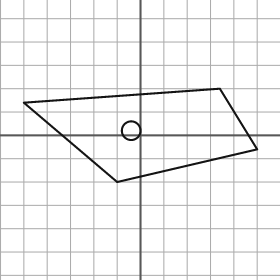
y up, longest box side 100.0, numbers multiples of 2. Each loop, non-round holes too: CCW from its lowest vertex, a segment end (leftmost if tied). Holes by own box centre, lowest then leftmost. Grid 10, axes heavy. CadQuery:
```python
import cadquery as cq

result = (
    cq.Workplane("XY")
    .moveTo(-10.0, -20.0)
    .lineTo(50.0, -6.0)
    .lineTo(34.0, 20.0)
    .lineTo(-50.0, 14.0)
    .close()
    .moveTo(-4.0, 2.0)
    .circle(4.0)
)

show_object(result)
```